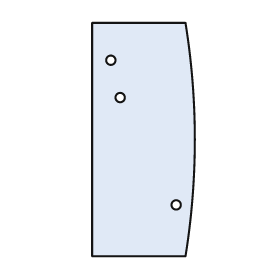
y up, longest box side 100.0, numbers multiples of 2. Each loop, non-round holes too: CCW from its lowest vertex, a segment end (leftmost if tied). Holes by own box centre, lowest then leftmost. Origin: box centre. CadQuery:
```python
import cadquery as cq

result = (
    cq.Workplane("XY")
    .moveTo(-22.0, -50.0)
    .lineTo(18.0, -50.0)
    .threePointArc((22.0, 0.0), (18.0, 50.0))
    .lineTo(-22.0, 50.0)
    .close()
    .moveTo(14.0, -28.0)
    .circle(2.0)
    .moveTo(-10.0, 18.0)
    .circle(2.0)
    .moveTo(-14.0, 34.0)
    .circle(2.0)
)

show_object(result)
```